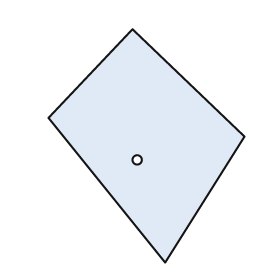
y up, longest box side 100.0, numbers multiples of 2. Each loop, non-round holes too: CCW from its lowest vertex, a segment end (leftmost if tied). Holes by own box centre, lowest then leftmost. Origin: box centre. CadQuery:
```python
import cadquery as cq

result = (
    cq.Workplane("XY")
    .moveTo(8.0, -50.0)
    .lineTo(42.0, 4.0)
    .lineTo(-6.0, 50.0)
    .lineTo(-42.0, 12.0)
    .close()
    .moveTo(-4.0, -6.0)
    .circle(2.0)
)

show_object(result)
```